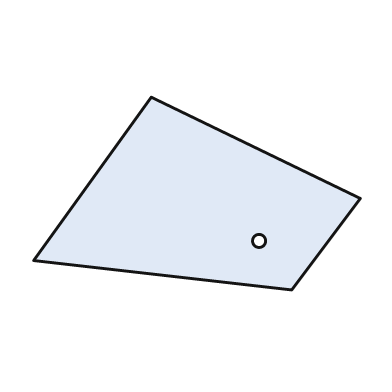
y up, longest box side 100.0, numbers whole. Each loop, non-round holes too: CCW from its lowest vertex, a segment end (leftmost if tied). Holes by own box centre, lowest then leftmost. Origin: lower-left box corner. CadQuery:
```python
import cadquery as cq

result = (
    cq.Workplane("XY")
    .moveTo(79.0, 0.0)
    .lineTo(100.0, 28.0)
    .lineTo(36.0, 59.0)
    .lineTo(0.0, 9.0)
    .close()
    .moveTo(69.0, 15.0)
    .circle(2.0)
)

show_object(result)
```